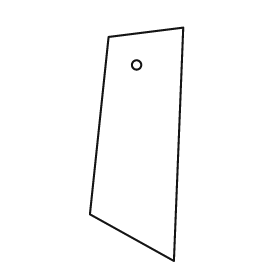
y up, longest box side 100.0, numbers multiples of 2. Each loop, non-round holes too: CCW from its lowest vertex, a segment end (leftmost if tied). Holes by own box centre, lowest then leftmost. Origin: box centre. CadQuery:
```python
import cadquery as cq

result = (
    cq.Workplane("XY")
    .moveTo(16.0, -50.0)
    .lineTo(20.0, 50.0)
    .lineTo(-12.0, 46.0)
    .lineTo(-20.0, -30.0)
    .close()
    .moveTo(0.0, 34.0)
    .circle(2.0)
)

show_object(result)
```